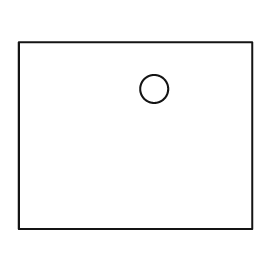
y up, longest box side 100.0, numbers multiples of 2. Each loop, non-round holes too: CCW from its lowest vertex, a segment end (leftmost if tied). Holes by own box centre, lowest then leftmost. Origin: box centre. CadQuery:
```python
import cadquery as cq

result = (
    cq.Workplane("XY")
    .moveTo(-50.0, -40.0)
    .lineTo(50.0, -40.0)
    .lineTo(50.0, 40.0)
    .lineTo(-50.0, 40.0)
    .close()
    .moveTo(8.0, 20.0)
    .circle(6.0)
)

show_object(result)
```